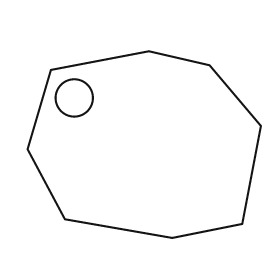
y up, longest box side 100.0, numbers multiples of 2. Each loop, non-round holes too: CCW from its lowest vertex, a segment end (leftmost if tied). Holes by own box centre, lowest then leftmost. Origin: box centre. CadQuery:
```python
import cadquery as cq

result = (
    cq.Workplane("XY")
    .moveTo(12.0, -40.0)
    .lineTo(42.0, -34.0)
    .lineTo(50.0, 8.0)
    .lineTo(28.0, 34.0)
    .lineTo(2.0, 40.0)
    .lineTo(-40.0, 32.0)
    .lineTo(-50.0, -2.0)
    .lineTo(-34.0, -32.0)
    .close()
    .moveTo(-30.0, 20.0)
    .circle(8.0)
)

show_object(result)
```